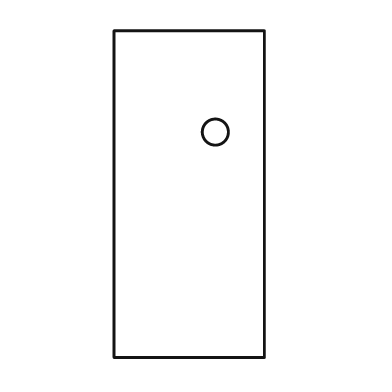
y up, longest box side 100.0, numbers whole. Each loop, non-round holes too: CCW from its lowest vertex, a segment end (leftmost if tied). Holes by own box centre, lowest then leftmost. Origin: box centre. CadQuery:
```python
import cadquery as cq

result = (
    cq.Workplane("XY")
    .moveTo(-23.0, -50.0)
    .lineTo(23.0, -50.0)
    .lineTo(23.0, 50.0)
    .lineTo(-23.0, 50.0)
    .close()
    .moveTo(8.0, 19.0)
    .circle(4.0)
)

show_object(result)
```